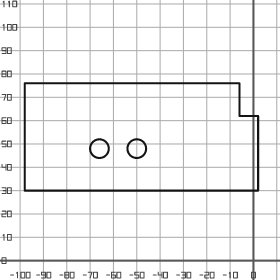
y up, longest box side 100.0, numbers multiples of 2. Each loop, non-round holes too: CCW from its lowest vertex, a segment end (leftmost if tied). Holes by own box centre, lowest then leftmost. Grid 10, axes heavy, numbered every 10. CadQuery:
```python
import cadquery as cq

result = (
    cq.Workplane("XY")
    .moveTo(-98.0, 30.0)
    .lineTo(2.0, 30.0)
    .lineTo(2.0, 62.0)
    .lineTo(-6.0, 62.0)
    .lineTo(-6.0, 76.0)
    .lineTo(-98.0, 76.0)
    .close()
    .moveTo(-66.0, 48.0)
    .circle(4.0)
    .moveTo(-50.0, 48.0)
    .circle(4.0)
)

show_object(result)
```